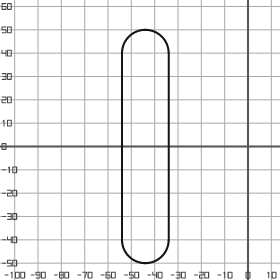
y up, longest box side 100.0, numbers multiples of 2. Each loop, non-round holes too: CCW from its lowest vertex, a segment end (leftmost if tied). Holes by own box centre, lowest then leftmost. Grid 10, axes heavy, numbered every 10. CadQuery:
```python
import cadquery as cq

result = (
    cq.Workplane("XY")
    .moveTo(-54.0, -40.0)
    .threePointArc((-44.0, -50.0), (-34.0, -40.0))
    .lineTo(-34.0, 40.0)
    .threePointArc((-44.0, 50.0), (-54.0, 40.0))
    .close()
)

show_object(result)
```